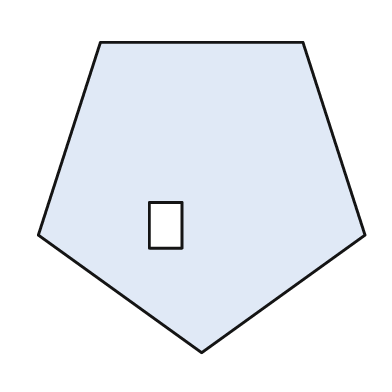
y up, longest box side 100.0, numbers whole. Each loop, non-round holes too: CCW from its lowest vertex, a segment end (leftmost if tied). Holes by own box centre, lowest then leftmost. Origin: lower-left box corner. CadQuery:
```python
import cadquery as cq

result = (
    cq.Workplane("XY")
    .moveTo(50.0, 0.0)
    .lineTo(100.0, 36.0)
    .lineTo(81.0, 95.0)
    .lineTo(19.0, 95.0)
    .lineTo(0.0, 36.0)
    .close()
    .moveTo(34.0, 32.0)
    .lineTo(44.0, 32.0)
    .lineTo(44.0, 46.0)
    .lineTo(34.0, 46.0)
    .close()
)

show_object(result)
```